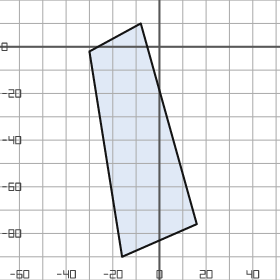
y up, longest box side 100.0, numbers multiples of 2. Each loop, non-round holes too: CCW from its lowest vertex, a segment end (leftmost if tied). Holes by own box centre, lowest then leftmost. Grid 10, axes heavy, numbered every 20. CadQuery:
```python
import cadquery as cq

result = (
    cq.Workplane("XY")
    .moveTo(-16.0, -90.0)
    .lineTo(16.0, -76.0)
    .lineTo(-8.0, 10.0)
    .lineTo(-30.0, -2.0)
    .close()
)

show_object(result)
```